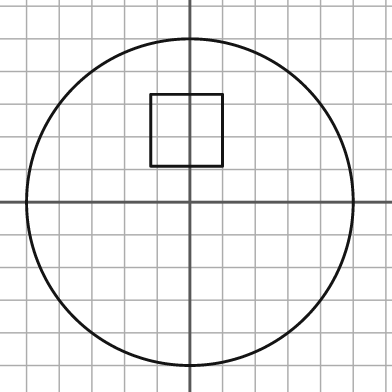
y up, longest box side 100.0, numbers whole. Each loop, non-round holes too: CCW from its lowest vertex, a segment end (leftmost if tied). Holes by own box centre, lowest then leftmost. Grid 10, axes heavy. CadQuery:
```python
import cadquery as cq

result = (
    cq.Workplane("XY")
    .moveTo(0.0, 0.0)
    .circle(50.0)
    .moveTo(-12.0, 11.0)
    .lineTo(10.0, 11.0)
    .lineTo(10.0, 33.0)
    .lineTo(-12.0, 33.0)
    .close()
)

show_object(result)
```